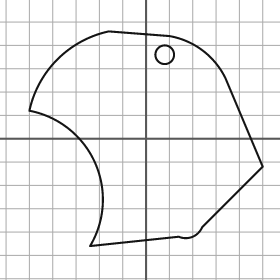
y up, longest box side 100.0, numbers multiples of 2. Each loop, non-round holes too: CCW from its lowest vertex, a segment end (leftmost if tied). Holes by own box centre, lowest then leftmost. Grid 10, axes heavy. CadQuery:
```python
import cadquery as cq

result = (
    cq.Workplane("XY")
    .moveTo(-24.0, -46.0)
    .lineTo(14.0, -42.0)
    .threePointArc((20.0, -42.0), (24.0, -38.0))
    .lineTo(50.0, -12.0)
    .lineTo(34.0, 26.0)
    .threePointArc((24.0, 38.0), (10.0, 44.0))
    .lineTo(-16.0, 46.0)
    .threePointArc((-38.0, 34.0), (-50.0, 12.0))
    .threePointArc((-22.0, -10.0), (-24.0, -46.0))
    .close()
    .moveTo(8.0, 36.0)
    .circle(4.0)
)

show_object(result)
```